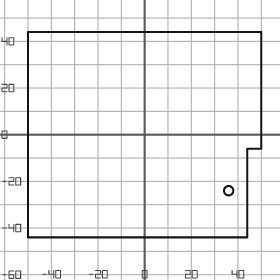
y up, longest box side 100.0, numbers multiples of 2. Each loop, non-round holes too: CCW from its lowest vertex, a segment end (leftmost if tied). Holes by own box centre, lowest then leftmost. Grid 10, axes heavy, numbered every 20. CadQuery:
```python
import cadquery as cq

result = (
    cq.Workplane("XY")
    .moveTo(-50.0, -44.0)
    .lineTo(44.0, -44.0)
    .lineTo(44.0, -6.0)
    .lineTo(50.0, -6.0)
    .lineTo(50.0, 44.0)
    .lineTo(-50.0, 44.0)
    .close()
    .moveTo(36.0, -24.0)
    .circle(2.0)
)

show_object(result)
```